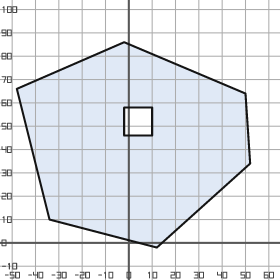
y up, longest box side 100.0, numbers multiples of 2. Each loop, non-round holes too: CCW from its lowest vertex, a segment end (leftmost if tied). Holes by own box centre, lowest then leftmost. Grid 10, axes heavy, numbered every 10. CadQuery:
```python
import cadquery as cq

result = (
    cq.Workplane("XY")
    .moveTo(12.0, -2.0)
    .lineTo(52.0, 34.0)
    .lineTo(50.0, 64.0)
    .lineTo(-2.0, 86.0)
    .lineTo(-48.0, 66.0)
    .lineTo(-34.0, 10.0)
    .close()
    .moveTo(-2.0, 46.0)
    .lineTo(10.0, 46.0)
    .lineTo(10.0, 58.0)
    .lineTo(-2.0, 58.0)
    .close()
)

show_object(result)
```